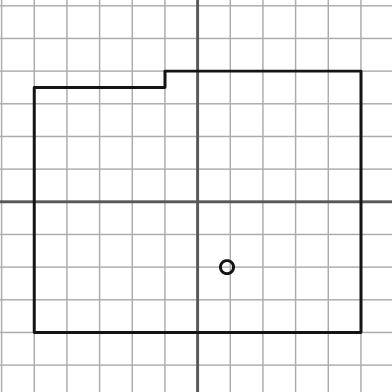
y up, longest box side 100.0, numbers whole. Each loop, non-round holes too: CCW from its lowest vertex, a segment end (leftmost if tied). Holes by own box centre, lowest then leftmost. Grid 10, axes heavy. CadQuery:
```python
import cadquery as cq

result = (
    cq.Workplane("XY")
    .moveTo(-50.0, -40.0)
    .lineTo(50.0, -40.0)
    .lineTo(50.0, 40.0)
    .lineTo(-10.0, 40.0)
    .lineTo(-10.0, 35.0)
    .lineTo(-50.0, 35.0)
    .close()
    .moveTo(9.0, -20.0)
    .circle(2.0)
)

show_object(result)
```